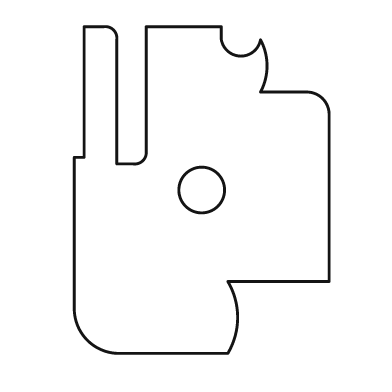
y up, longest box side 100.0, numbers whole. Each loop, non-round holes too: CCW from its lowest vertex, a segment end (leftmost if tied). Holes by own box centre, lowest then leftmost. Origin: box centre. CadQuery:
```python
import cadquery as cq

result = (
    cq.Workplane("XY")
    .moveTo(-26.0, -50.0)
    .lineTo(8.0, -50.0)
    .threePointArc((11.0, -39.0), (8.0, -28.0))
    .lineTo(39.0, -28.0)
    .lineTo(39.0, 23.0)
    .threePointArc((37.0, 28.0), (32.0, 30.0))
    .lineTo(18.0, 30.0)
    .threePointArc((20.0, 38.0), (18.0, 46.0))
    .threePointArc((12.0, 41.0), (6.0, 46.0))
    .lineTo(6.0, 50.0)
    .lineTo(-17.0, 50.0)
    .lineTo(-17.0, 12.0)
    .threePointArc((-18.0, 9.0), (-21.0, 8.0))
    .lineTo(-26.0, 8.0)
    .lineTo(-26.0, 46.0)
    .threePointArc((-27.0, 49.0), (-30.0, 50.0))
    .lineTo(-36.0, 50.0)
    .lineTo(-36.0, 10.0)
    .lineTo(-39.0, 10.0)
    .lineTo(-39.0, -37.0)
    .threePointArc((-35.0, -46.0), (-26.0, -50.0))
    .close()
    .moveTo(0.0, 0.0)
    .circle(7.0)
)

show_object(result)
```